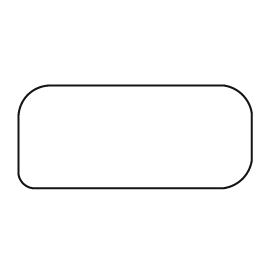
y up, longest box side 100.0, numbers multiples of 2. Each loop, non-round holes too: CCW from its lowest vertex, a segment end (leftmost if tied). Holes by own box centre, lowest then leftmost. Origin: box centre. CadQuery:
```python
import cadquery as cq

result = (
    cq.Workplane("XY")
    .moveTo(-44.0, -22.0)
    .lineTo(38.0, -22.0)
    .threePointArc((46.0, -18.0), (50.0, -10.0))
    .lineTo(50.0, 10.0)
    .threePointArc((46.0, 18.0), (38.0, 22.0))
    .lineTo(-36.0, 22.0)
    .threePointArc((-46.0, 18.0), (-50.0, 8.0))
    .lineTo(-50.0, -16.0)
    .threePointArc((-48.0, -20.0), (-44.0, -22.0))
    .close()
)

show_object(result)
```